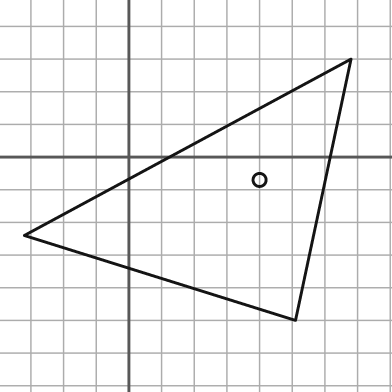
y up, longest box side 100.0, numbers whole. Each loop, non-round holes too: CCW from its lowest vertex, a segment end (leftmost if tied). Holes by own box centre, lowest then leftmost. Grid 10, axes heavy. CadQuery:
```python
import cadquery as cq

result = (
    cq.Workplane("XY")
    .moveTo(51.0, -50.0)
    .lineTo(68.0, 30.0)
    .lineTo(-32.0, -24.0)
    .close()
    .moveTo(40.0, -7.0)
    .circle(2.0)
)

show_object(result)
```